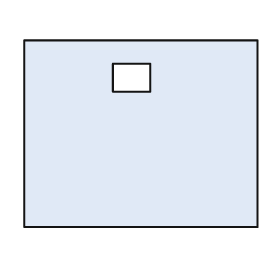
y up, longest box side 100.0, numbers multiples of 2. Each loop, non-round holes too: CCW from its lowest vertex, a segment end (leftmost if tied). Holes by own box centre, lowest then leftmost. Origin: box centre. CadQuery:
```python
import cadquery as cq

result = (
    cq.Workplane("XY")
    .moveTo(-50.0, -40.0)
    .lineTo(50.0, -40.0)
    .lineTo(50.0, 40.0)
    .lineTo(-50.0, 40.0)
    .close()
    .moveTo(-12.0, 18.0)
    .lineTo(4.0, 18.0)
    .lineTo(4.0, 30.0)
    .lineTo(-12.0, 30.0)
    .close()
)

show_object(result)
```